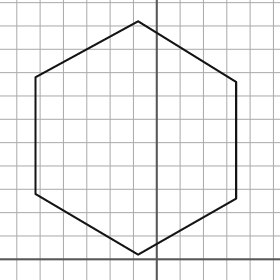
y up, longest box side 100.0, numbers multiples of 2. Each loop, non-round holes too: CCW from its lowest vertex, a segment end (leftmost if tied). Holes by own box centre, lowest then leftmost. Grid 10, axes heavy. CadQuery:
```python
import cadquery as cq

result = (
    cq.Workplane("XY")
    .moveTo(-8.0, 2.0)
    .lineTo(34.0, 26.0)
    .lineTo(34.0, 76.0)
    .lineTo(-8.0, 102.0)
    .lineTo(-52.0, 78.0)
    .lineTo(-52.0, 28.0)
    .close()
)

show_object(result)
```